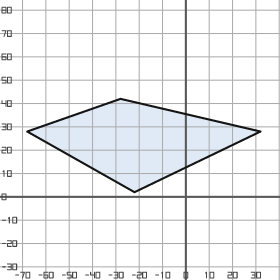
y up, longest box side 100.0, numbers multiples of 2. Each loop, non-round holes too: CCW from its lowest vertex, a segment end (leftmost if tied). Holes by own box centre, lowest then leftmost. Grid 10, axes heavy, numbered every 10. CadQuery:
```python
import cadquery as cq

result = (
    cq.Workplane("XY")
    .moveTo(-22.0, 2.0)
    .lineTo(32.0, 28.0)
    .lineTo(-28.0, 42.0)
    .lineTo(-68.0, 28.0)
    .close()
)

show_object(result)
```